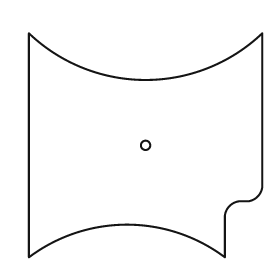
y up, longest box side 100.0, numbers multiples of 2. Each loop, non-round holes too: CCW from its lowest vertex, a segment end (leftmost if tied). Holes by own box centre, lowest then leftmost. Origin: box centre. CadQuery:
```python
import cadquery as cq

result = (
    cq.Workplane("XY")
    .moveTo(-50.0, -48.0)
    .threePointArc((-8.0, -34.0), (34.0, -48.0))
    .lineTo(34.0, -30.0)
    .threePointArc((36.0, -26.0), (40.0, -24.0))
    .lineTo(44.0, -24.0)
    .threePointArc((48.0, -22.0), (50.0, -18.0))
    .lineTo(50.0, 48.0)
    .threePointArc((0.0, 28.0), (-50.0, 48.0))
    .close()
    .moveTo(0.0, 0.0)
    .circle(2.0)
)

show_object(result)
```